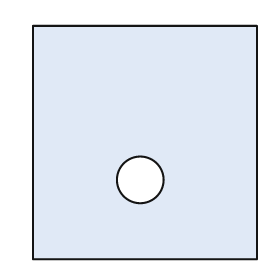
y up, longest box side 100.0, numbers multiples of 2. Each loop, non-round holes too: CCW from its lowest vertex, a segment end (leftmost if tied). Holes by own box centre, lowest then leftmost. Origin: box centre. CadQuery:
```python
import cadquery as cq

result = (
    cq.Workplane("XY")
    .moveTo(-48.0, -50.0)
    .lineTo(48.0, -50.0)
    .lineTo(48.0, 50.0)
    .lineTo(-48.0, 50.0)
    .close()
    .moveTo(-2.0, -16.0)
    .circle(10.0)
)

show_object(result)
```